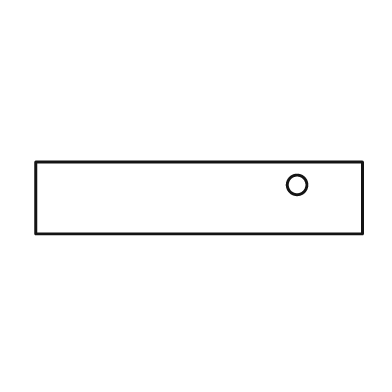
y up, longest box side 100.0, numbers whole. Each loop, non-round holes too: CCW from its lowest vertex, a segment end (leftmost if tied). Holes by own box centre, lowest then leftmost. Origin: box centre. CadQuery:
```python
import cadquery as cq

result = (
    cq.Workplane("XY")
    .moveTo(-50.0, -11.0)
    .lineTo(50.0, -11.0)
    .lineTo(50.0, 11.0)
    .lineTo(-50.0, 11.0)
    .close()
    .moveTo(30.0, 4.0)
    .circle(3.0)
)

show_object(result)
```